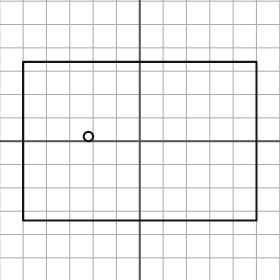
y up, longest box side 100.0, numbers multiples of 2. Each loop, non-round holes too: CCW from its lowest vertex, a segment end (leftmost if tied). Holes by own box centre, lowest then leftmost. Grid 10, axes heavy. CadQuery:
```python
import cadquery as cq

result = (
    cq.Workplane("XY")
    .moveTo(-50.0, -34.0)
    .lineTo(50.0, -34.0)
    .lineTo(50.0, 34.0)
    .lineTo(-50.0, 34.0)
    .close()
    .moveTo(-22.0, 2.0)
    .circle(2.0)
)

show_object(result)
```